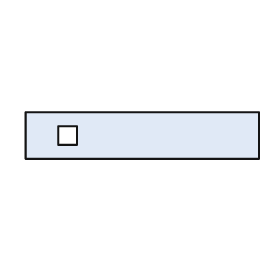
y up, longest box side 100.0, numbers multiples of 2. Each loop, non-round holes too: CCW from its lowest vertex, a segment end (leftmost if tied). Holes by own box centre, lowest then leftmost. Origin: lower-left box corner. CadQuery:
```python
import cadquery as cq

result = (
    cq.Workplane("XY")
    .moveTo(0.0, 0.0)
    .lineTo(100.0, 0.0)
    .lineTo(100.0, 20.0)
    .lineTo(0.0, 20.0)
    .close()
    .moveTo(14.0, 6.0)
    .lineTo(22.0, 6.0)
    .lineTo(22.0, 14.0)
    .lineTo(14.0, 14.0)
    .close()
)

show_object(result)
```